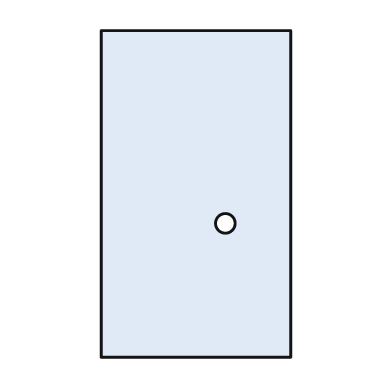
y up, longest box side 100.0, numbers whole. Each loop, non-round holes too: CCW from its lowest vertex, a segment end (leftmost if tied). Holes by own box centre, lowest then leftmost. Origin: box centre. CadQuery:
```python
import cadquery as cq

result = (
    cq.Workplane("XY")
    .moveTo(-29.0, -50.0)
    .lineTo(29.0, -50.0)
    .lineTo(29.0, 50.0)
    .lineTo(-29.0, 50.0)
    .close()
    .moveTo(9.0, -9.0)
    .circle(3.0)
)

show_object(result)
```